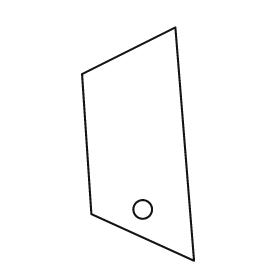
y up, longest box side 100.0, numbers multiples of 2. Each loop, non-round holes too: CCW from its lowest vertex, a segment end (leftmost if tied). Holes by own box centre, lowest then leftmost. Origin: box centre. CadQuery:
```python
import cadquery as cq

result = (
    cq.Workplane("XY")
    .moveTo(24.0, -50.0)
    .lineTo(16.0, 50.0)
    .lineTo(-24.0, 30.0)
    .lineTo(-20.0, -30.0)
    .close()
    .moveTo(2.0, -28.0)
    .circle(4.0)
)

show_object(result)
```